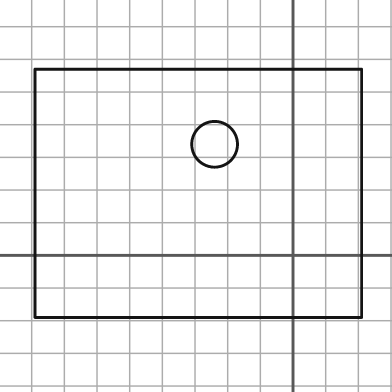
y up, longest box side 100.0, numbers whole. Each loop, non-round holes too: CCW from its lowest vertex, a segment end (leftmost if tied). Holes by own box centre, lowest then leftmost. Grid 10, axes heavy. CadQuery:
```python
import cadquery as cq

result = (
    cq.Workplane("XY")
    .moveTo(-79.0, -19.0)
    .lineTo(21.0, -19.0)
    .lineTo(21.0, 57.0)
    .lineTo(-79.0, 57.0)
    .close()
    .moveTo(-24.0, 34.0)
    .circle(7.0)
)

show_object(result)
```